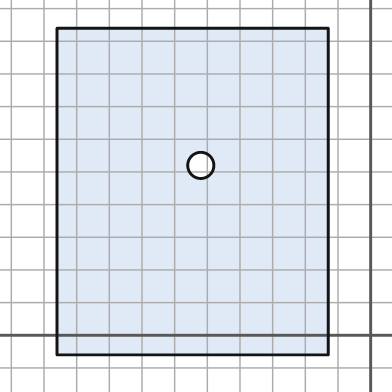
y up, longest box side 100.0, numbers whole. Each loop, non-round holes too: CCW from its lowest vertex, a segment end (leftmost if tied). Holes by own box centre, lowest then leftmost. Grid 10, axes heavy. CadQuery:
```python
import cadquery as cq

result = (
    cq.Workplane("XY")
    .moveTo(-96.0, -6.0)
    .lineTo(-13.0, -6.0)
    .lineTo(-13.0, 94.0)
    .lineTo(-96.0, 94.0)
    .close()
    .moveTo(-52.0, 52.0)
    .circle(4.0)
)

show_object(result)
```